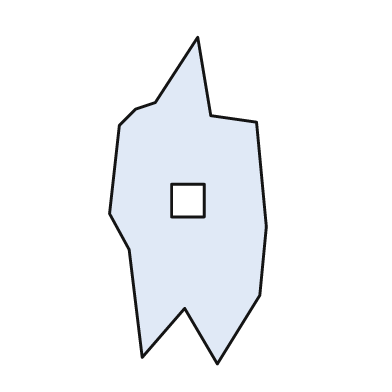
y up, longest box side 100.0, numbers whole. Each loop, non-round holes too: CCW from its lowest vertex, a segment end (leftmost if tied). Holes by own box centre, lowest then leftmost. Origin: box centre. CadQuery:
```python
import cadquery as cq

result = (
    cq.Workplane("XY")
    .moveTo(9.0, -50.0)
    .lineTo(22.0, -29.0)
    .lineTo(24.0, -8.0)
    .lineTo(21.0, 24.0)
    .lineTo(7.0, 26.0)
    .lineTo(3.0, 50.0)
    .lineTo(-10.0, 30.0)
    .lineTo(-16.0, 28.0)
    .lineTo(-21.0, 23.0)
    .lineTo(-24.0, -4.0)
    .lineTo(-18.0, -15.0)
    .lineTo(-14.0, -48.0)
    .lineTo(-1.0, -33.0)
    .close()
    .moveTo(-5.0, -5.0)
    .lineTo(5.0, -5.0)
    .lineTo(5.0, 5.0)
    .lineTo(-5.0, 5.0)
    .close()
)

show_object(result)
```